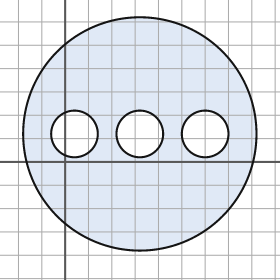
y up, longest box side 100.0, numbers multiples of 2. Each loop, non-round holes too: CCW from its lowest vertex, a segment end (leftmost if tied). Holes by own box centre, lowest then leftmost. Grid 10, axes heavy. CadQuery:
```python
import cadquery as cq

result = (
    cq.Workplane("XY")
    .moveTo(32.0, 12.0)
    .circle(50.0)
    .moveTo(4.0, 12.0)
    .circle(10.0)
    .moveTo(32.0, 12.0)
    .circle(10.0)
    .moveTo(60.0, 12.0)
    .circle(10.0)
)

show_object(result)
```